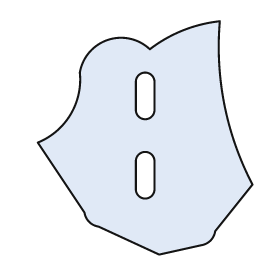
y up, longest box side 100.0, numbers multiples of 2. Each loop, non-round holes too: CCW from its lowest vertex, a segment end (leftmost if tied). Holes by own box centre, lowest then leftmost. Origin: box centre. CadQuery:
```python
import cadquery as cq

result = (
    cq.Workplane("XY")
    .moveTo(6.0, -50.0)
    .lineTo(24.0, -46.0)
    .threePointArc((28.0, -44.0), (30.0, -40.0))
    .lineTo(46.0, -20.0)
    .threePointArc((34.0, 14.0), (32.0, 50.0))
    .threePointArc((16.0, 46.0), (2.0, 38.0))
    .threePointArc((-16.0, 42.0), (-28.0, 28.0))
    .threePointArc((-32.0, 10.0), (-46.0, -2.0))
    .lineTo(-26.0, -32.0)
    .threePointArc((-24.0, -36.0), (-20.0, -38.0))
    .close()
    .moveTo(-4.0, -22.0)
    .threePointArc((0.0, -26.0), (4.0, -22.0))
    .lineTo(4.0, -10.0)
    .threePointArc((0.0, -6.0), (-4.0, -10.0))
    .close()
    .moveTo(-4.0, 12.0)
    .threePointArc((0.0, 8.0), (4.0, 12.0))
    .lineTo(4.0, 24.0)
    .threePointArc((0.0, 28.0), (-4.0, 24.0))
    .close()
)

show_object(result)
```